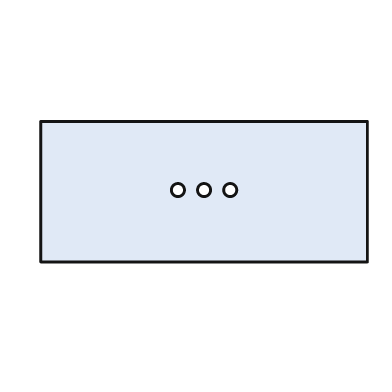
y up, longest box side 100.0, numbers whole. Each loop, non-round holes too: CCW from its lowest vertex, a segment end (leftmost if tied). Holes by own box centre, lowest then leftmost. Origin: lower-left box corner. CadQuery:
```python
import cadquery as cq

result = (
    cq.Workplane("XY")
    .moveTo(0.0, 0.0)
    .lineTo(100.0, 0.0)
    .lineTo(100.0, 43.0)
    .lineTo(0.0, 43.0)
    .close()
    .moveTo(42.0, 22.0)
    .circle(2.0)
    .moveTo(50.0, 22.0)
    .circle(2.0)
    .moveTo(58.0, 22.0)
    .circle(2.0)
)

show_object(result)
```